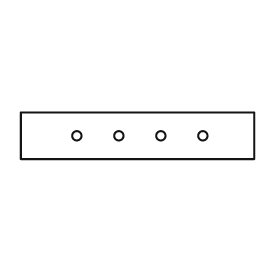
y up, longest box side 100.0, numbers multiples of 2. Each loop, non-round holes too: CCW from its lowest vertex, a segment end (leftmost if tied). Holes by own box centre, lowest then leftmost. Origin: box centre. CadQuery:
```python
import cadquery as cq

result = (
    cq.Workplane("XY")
    .moveTo(-50.0, -10.0)
    .lineTo(50.0, -10.0)
    .lineTo(50.0, 10.0)
    .lineTo(-50.0, 10.0)
    .close()
    .moveTo(-26.0, 0.0)
    .circle(2.0)
    .moveTo(-8.0, 0.0)
    .circle(2.0)
    .moveTo(10.0, 0.0)
    .circle(2.0)
    .moveTo(28.0, 0.0)
    .circle(2.0)
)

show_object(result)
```